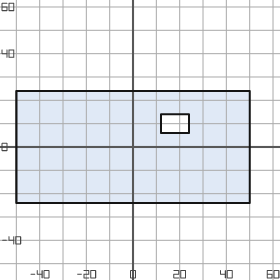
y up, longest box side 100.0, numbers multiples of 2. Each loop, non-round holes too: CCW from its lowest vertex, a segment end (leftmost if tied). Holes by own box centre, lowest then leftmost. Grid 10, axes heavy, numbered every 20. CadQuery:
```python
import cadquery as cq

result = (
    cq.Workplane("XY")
    .moveTo(-50.0, -24.0)
    .lineTo(50.0, -24.0)
    .lineTo(50.0, 24.0)
    .lineTo(-50.0, 24.0)
    .close()
    .moveTo(12.0, 6.0)
    .lineTo(24.0, 6.0)
    .lineTo(24.0, 14.0)
    .lineTo(12.0, 14.0)
    .close()
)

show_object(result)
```